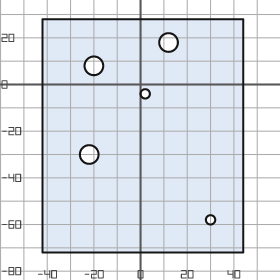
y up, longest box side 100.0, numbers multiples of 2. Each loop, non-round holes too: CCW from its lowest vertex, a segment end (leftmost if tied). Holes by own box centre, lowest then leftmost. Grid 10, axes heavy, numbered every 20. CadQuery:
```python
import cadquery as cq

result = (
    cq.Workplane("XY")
    .moveTo(-42.0, -72.0)
    .lineTo(44.0, -72.0)
    .lineTo(44.0, 28.0)
    .lineTo(-42.0, 28.0)
    .close()
    .moveTo(30.0, -58.0)
    .circle(2.0)
    .moveTo(-22.0, -30.0)
    .circle(4.0)
    .moveTo(2.0, -4.0)
    .circle(2.0)
    .moveTo(-20.0, 8.0)
    .circle(4.0)
    .moveTo(12.0, 18.0)
    .circle(4.0)
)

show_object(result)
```